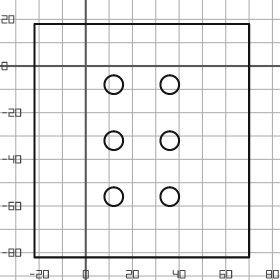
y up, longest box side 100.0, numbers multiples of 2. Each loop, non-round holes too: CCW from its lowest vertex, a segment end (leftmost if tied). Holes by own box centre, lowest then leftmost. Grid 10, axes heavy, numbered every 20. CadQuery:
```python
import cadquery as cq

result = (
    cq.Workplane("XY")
    .moveTo(-22.0, -82.0)
    .lineTo(70.0, -82.0)
    .lineTo(70.0, 18.0)
    .lineTo(-22.0, 18.0)
    .close()
    .moveTo(12.0, -56.0)
    .circle(4.0)
    .moveTo(36.0, -56.0)
    .circle(4.0)
    .moveTo(12.0, -32.0)
    .circle(4.0)
    .moveTo(36.0, -32.0)
    .circle(4.0)
    .moveTo(12.0, -8.0)
    .circle(4.0)
    .moveTo(36.0, -8.0)
    .circle(4.0)
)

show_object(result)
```